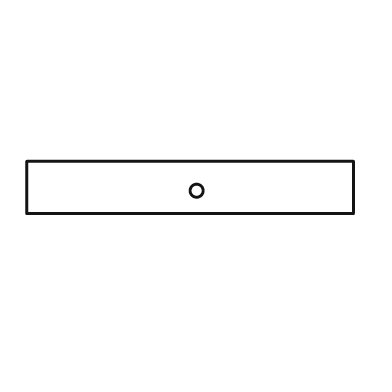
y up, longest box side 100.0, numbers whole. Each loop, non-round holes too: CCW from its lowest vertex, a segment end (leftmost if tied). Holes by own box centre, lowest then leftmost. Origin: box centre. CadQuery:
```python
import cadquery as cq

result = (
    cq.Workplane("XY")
    .moveTo(-50.0, -8.0)
    .lineTo(50.0, -8.0)
    .lineTo(50.0, 8.0)
    .lineTo(-50.0, 8.0)
    .close()
    .moveTo(2.0, -1.0)
    .circle(2.0)
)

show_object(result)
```